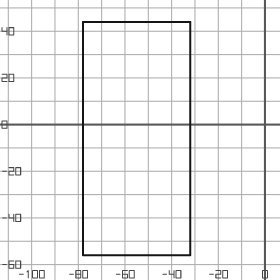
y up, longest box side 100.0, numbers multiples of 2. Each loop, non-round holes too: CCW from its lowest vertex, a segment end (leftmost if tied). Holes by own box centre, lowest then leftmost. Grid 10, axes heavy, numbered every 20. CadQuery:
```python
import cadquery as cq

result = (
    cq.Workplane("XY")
    .moveTo(-78.0, -56.0)
    .lineTo(-32.0, -56.0)
    .lineTo(-32.0, 44.0)
    .lineTo(-78.0, 44.0)
    .close()
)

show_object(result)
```